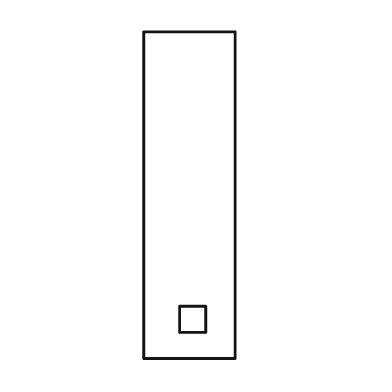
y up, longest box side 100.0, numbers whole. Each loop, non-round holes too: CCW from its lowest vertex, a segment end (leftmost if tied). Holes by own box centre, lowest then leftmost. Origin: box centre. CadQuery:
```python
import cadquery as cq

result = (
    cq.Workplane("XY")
    .moveTo(-14.0, -50.0)
    .lineTo(14.0, -50.0)
    .lineTo(14.0, 50.0)
    .lineTo(-14.0, 50.0)
    .close()
    .moveTo(-3.0, -42.0)
    .lineTo(5.0, -42.0)
    .lineTo(5.0, -34.0)
    .lineTo(-3.0, -34.0)
    .close()
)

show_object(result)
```